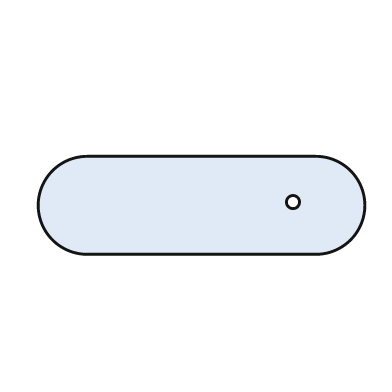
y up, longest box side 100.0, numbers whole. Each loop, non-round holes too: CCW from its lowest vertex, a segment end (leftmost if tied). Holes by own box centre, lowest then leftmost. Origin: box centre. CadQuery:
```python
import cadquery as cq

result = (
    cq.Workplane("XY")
    .moveTo(-35.0, -15.0)
    .lineTo(35.0, -15.0)
    .threePointArc((50.0, 0.0), (35.0, 15.0))
    .lineTo(-35.0, 15.0)
    .threePointArc((-50.0, 0.0), (-35.0, -15.0))
    .close()
    .moveTo(28.0, 1.0)
    .circle(2.0)
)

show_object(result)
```